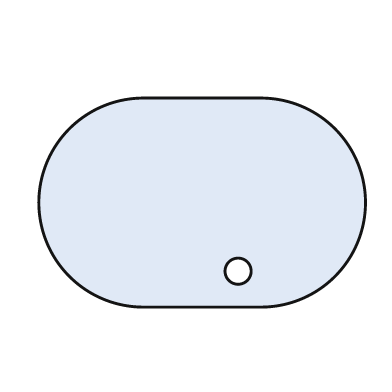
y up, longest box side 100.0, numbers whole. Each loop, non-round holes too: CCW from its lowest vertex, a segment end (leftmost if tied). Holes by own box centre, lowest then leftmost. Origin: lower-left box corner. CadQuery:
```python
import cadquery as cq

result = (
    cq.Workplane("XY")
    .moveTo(32.0, 0.0)
    .lineTo(68.0, 0.0)
    .threePointArc((100.0, 32.0), (68.0, 64.0))
    .lineTo(32.0, 64.0)
    .threePointArc((0.0, 32.0), (32.0, 0.0))
    .close()
    .moveTo(61.0, 11.0)
    .circle(4.0)
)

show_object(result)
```